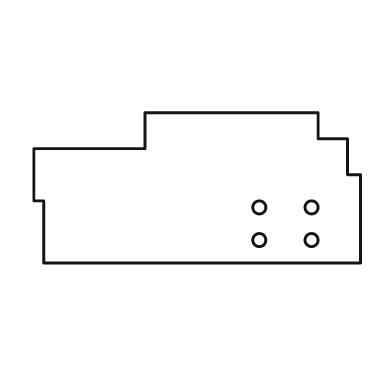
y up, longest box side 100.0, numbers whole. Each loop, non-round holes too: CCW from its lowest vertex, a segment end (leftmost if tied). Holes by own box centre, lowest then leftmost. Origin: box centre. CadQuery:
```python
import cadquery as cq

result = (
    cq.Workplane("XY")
    .moveTo(-47.0, -23.0)
    .lineTo(50.0, -23.0)
    .lineTo(50.0, 4.0)
    .lineTo(46.0, 4.0)
    .lineTo(46.0, 15.0)
    .lineTo(37.0, 15.0)
    .lineTo(37.0, 23.0)
    .lineTo(-16.0, 23.0)
    .lineTo(-16.0, 12.0)
    .lineTo(-50.0, 12.0)
    .lineTo(-50.0, -4.0)
    .lineTo(-47.0, -4.0)
    .close()
    .moveTo(19.0, -16.0)
    .circle(2.0)
    .moveTo(35.0, -16.0)
    .circle(2.0)
    .moveTo(19.0, -6.0)
    .circle(2.0)
    .moveTo(35.0, -6.0)
    .circle(2.0)
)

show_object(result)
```